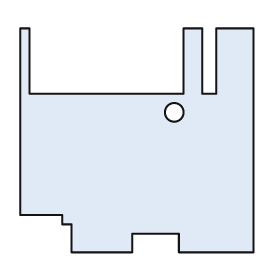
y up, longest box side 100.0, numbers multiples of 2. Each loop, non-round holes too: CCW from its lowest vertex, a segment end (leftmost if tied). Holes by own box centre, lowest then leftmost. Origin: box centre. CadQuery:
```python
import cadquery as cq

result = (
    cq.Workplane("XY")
    .moveTo(-28.0, -48.0)
    .lineTo(-2.0, -48.0)
    .lineTo(-2.0, -40.0)
    .lineTo(18.0, -40.0)
    .lineTo(18.0, -48.0)
    .lineTo(50.0, -48.0)
    .lineTo(50.0, 48.0)
    .lineTo(34.0, 48.0)
    .lineTo(34.0, 20.0)
    .lineTo(28.0, 20.0)
    .lineTo(28.0, 48.0)
    .lineTo(20.0, 48.0)
    .lineTo(20.0, 20.0)
    .lineTo(-46.0, 20.0)
    .lineTo(-46.0, 48.0)
    .lineTo(-50.0, 48.0)
    .lineTo(-50.0, -32.0)
    .lineTo(-32.0, -32.0)
    .lineTo(-32.0, -36.0)
    .lineTo(-28.0, -36.0)
    .close()
    .moveTo(16.0, 12.0)
    .circle(4.0)
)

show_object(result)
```